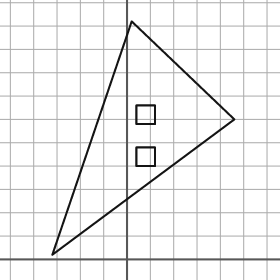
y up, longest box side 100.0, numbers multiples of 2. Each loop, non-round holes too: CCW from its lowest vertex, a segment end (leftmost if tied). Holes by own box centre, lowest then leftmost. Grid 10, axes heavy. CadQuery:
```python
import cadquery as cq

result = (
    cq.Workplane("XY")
    .moveTo(-32.0, 2.0)
    .lineTo(46.0, 60.0)
    .lineTo(2.0, 102.0)
    .close()
    .moveTo(4.0, 40.0)
    .lineTo(12.0, 40.0)
    .lineTo(12.0, 48.0)
    .lineTo(4.0, 48.0)
    .close()
    .moveTo(4.0, 58.0)
    .lineTo(12.0, 58.0)
    .lineTo(12.0, 66.0)
    .lineTo(4.0, 66.0)
    .close()
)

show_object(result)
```